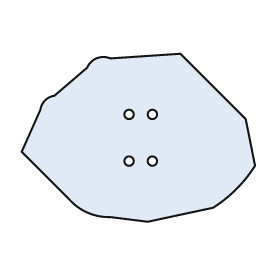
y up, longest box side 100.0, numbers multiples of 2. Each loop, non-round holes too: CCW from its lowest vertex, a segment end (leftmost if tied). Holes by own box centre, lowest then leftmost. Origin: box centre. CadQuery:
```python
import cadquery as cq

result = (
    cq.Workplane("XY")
    .moveTo(4.0, -36.0)
    .lineTo(32.0, -30.0)
    .threePointArc((42.0, -22.0), (50.0, -12.0))
    .lineTo(46.0, 8.0)
    .lineTo(18.0, 36.0)
    .lineTo(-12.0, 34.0)
    .threePointArc((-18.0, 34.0), (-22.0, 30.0))
    .lineTo(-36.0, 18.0)
    .threePointArc((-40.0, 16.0), (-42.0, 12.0))
    .lineTo(-50.0, -6.0)
    .lineTo(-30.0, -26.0)
    .threePointArc((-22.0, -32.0), (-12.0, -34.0))
    .close()
    .moveTo(-4.0, -10.0)
    .circle(2.0)
    .moveTo(6.0, -10.0)
    .circle(2.0)
    .moveTo(-4.0, 10.0)
    .circle(2.0)
    .moveTo(6.0, 10.0)
    .circle(2.0)
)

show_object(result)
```